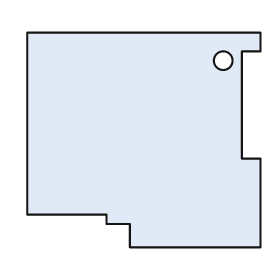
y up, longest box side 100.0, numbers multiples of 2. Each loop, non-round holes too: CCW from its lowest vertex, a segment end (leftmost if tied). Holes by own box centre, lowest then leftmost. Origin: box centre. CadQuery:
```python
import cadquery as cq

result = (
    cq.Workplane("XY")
    .moveTo(-6.0, -46.0)
    .lineTo(50.0, -46.0)
    .lineTo(50.0, -8.0)
    .lineTo(42.0, -8.0)
    .lineTo(42.0, 38.0)
    .lineTo(50.0, 38.0)
    .lineTo(50.0, 46.0)
    .lineTo(-50.0, 46.0)
    .lineTo(-50.0, -32.0)
    .lineTo(-16.0, -32.0)
    .lineTo(-16.0, -36.0)
    .lineTo(-6.0, -36.0)
    .close()
    .moveTo(34.0, 34.0)
    .circle(4.0)
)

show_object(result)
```